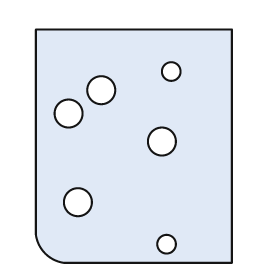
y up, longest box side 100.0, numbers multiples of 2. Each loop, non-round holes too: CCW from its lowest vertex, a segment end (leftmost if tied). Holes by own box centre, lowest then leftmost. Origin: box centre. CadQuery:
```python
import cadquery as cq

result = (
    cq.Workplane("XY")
    .moveTo(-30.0, -50.0)
    .lineTo(42.0, -50.0)
    .lineTo(42.0, 50.0)
    .lineTo(-42.0, 50.0)
    .lineTo(-42.0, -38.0)
    .threePointArc((-38.0, -46.0), (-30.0, -50.0))
    .close()
    .moveTo(14.0, -42.0)
    .circle(4.0)
    .moveTo(-24.0, -24.0)
    .circle(6.0)
    .moveTo(12.0, 2.0)
    .circle(6.0)
    .moveTo(-28.0, 14.0)
    .circle(6.0)
    .moveTo(-14.0, 24.0)
    .circle(6.0)
    .moveTo(16.0, 32.0)
    .circle(4.0)
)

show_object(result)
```